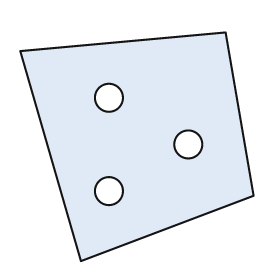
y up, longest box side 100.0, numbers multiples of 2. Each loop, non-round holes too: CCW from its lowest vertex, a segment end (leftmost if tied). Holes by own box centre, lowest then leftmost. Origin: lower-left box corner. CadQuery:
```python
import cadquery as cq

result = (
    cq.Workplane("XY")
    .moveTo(26.0, 0.0)
    .lineTo(100.0, 28.0)
    .lineTo(88.0, 98.0)
    .lineTo(0.0, 90.0)
    .close()
    .moveTo(38.0, 30.0)
    .circle(6.0)
    .moveTo(72.0, 50.0)
    .circle(6.0)
    .moveTo(38.0, 70.0)
    .circle(6.0)
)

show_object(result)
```